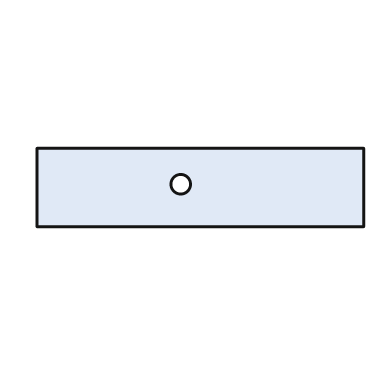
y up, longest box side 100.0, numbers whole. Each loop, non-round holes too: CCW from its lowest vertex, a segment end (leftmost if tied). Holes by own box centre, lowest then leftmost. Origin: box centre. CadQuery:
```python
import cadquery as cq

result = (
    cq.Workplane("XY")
    .moveTo(-50.0, -12.0)
    .lineTo(50.0, -12.0)
    .lineTo(50.0, 12.0)
    .lineTo(-50.0, 12.0)
    .close()
    .moveTo(-6.0, 1.0)
    .circle(3.0)
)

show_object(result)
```